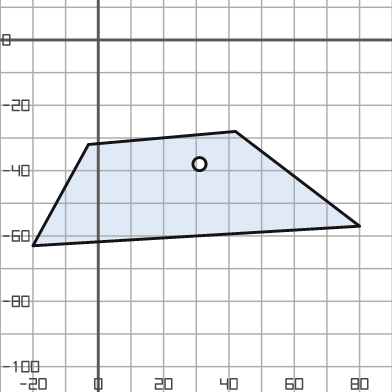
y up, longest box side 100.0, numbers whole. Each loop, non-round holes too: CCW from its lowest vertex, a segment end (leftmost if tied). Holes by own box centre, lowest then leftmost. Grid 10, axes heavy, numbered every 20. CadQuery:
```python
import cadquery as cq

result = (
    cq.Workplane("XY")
    .moveTo(-20.0, -63.0)
    .lineTo(80.0, -57.0)
    .lineTo(42.0, -28.0)
    .lineTo(-3.0, -32.0)
    .close()
    .moveTo(31.0, -38.0)
    .circle(2.0)
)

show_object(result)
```